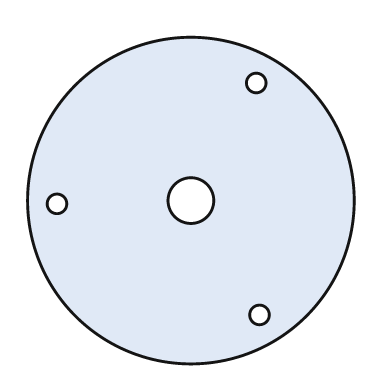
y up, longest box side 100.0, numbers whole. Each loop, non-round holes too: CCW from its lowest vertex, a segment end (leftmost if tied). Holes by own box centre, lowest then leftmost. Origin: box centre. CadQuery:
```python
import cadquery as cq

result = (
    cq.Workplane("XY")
    .moveTo(0.0, 0.0)
    .circle(50.0)
    .moveTo(21.0, -35.0)
    .circle(3.0)
    .moveTo(-41.0, -1.0)
    .circle(3.0)
    .moveTo(0.0, 0.0)
    .circle(7.0)
    .moveTo(20.0, 36.0)
    .circle(3.0)
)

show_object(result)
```